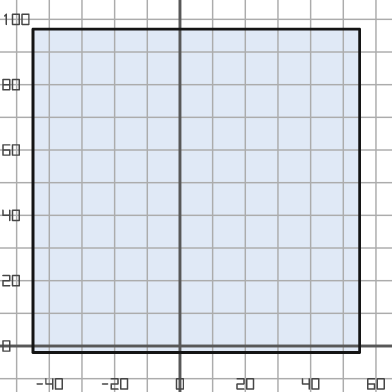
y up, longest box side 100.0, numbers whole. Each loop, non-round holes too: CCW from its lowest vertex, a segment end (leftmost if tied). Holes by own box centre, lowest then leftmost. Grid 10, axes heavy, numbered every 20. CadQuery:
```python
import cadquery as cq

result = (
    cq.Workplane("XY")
    .moveTo(-45.0, -2.0)
    .lineTo(55.0, -2.0)
    .lineTo(55.0, 97.0)
    .lineTo(-45.0, 97.0)
    .close()
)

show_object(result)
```